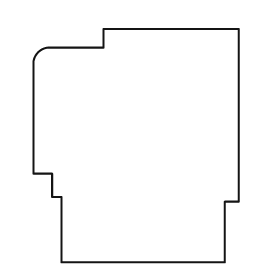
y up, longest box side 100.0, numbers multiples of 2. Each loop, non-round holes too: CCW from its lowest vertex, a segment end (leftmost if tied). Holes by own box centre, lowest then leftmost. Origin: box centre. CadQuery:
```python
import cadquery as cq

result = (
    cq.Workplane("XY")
    .moveTo(-32.0, -50.0)
    .lineTo(38.0, -50.0)
    .lineTo(38.0, -24.0)
    .lineTo(44.0, -24.0)
    .lineTo(44.0, 50.0)
    .lineTo(-14.0, 50.0)
    .lineTo(-14.0, 42.0)
    .lineTo(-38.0, 42.0)
    .threePointArc((-42.0, 40.0), (-44.0, 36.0))
    .lineTo(-44.0, -12.0)
    .lineTo(-36.0, -12.0)
    .lineTo(-36.0, -22.0)
    .lineTo(-32.0, -22.0)
    .close()
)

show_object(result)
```